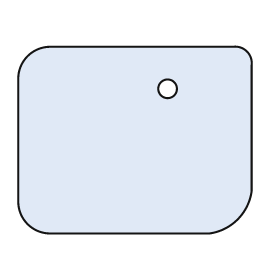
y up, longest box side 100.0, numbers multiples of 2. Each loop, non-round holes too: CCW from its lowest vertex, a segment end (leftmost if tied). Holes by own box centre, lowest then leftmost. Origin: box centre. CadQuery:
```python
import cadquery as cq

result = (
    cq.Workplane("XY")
    .moveTo(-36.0, -40.0)
    .lineTo(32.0, -40.0)
    .threePointArc((44.0, -34.0), (50.0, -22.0))
    .lineTo(50.0, 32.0)
    .threePointArc((48.0, 38.0), (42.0, 40.0))
    .lineTo(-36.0, 40.0)
    .threePointArc((-46.0, 36.0), (-50.0, 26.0))
    .lineTo(-50.0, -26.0)
    .threePointArc((-46.0, -36.0), (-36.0, -40.0))
    .close()
    .moveTo(14.0, 22.0)
    .circle(4.0)
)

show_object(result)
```